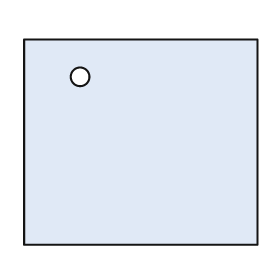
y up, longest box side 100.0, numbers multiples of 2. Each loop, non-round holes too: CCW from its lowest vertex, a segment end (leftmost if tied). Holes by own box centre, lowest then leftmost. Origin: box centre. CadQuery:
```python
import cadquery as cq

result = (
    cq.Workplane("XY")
    .moveTo(-50.0, -44.0)
    .lineTo(50.0, -44.0)
    .lineTo(50.0, 44.0)
    .lineTo(-50.0, 44.0)
    .close()
    .moveTo(-26.0, 28.0)
    .circle(4.0)
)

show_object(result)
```